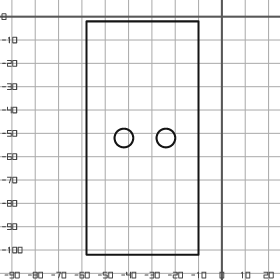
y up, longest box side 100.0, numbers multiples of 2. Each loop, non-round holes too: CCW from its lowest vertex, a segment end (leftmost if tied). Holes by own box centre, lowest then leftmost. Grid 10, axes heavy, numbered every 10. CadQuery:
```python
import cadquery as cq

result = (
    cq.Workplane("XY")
    .moveTo(-58.0, -102.0)
    .lineTo(-10.0, -102.0)
    .lineTo(-10.0, -2.0)
    .lineTo(-58.0, -2.0)
    .close()
    .moveTo(-42.0, -52.0)
    .circle(4.0)
    .moveTo(-24.0, -52.0)
    .circle(4.0)
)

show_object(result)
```